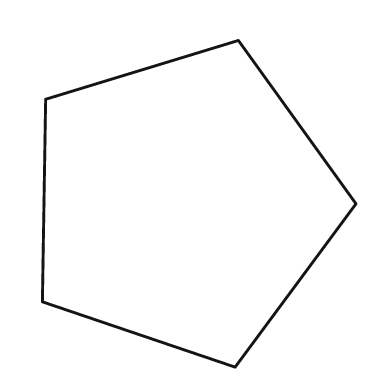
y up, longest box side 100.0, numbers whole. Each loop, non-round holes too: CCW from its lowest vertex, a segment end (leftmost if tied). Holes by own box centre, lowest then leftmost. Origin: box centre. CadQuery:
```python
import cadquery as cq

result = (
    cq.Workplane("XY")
    .moveTo(11.0, -50.0)
    .lineTo(48.0, 0.0)
    .lineTo(12.0, 50.0)
    .lineTo(-47.0, 32.0)
    .lineTo(-48.0, -30.0)
    .close()
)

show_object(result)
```